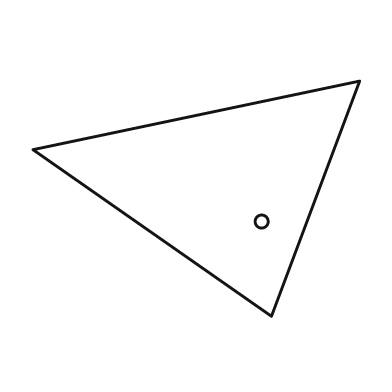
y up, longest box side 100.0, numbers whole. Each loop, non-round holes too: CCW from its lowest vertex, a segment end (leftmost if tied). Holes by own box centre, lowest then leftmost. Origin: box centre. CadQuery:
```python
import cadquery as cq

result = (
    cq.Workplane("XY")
    .moveTo(23.0, -36.0)
    .lineTo(50.0, 36.0)
    .lineTo(-50.0, 15.0)
    .close()
    .moveTo(20.0, -7.0)
    .circle(2.0)
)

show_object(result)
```